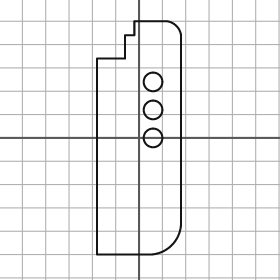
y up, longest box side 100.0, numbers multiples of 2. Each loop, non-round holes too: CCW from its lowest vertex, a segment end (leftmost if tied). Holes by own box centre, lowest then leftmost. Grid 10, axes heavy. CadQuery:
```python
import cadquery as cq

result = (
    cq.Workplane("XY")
    .moveTo(-18.0, -50.0)
    .lineTo(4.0, -50.0)
    .threePointArc((14.0, -46.0), (18.0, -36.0))
    .lineTo(18.0, 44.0)
    .threePointArc((16.0, 48.0), (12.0, 50.0))
    .lineTo(-2.0, 50.0)
    .lineTo(-2.0, 44.0)
    .lineTo(-6.0, 44.0)
    .lineTo(-6.0, 34.0)
    .lineTo(-18.0, 34.0)
    .close()
    .moveTo(6.0, 0.0)
    .circle(4.0)
    .moveTo(6.0, 12.0)
    .circle(4.0)
    .moveTo(6.0, 24.0)
    .circle(4.0)
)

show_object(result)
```